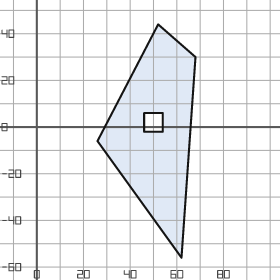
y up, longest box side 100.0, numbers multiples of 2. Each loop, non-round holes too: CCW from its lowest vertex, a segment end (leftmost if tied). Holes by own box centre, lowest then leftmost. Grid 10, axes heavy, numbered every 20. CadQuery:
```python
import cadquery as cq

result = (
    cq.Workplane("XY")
    .moveTo(62.0, -56.0)
    .lineTo(68.0, 30.0)
    .lineTo(52.0, 44.0)
    .lineTo(26.0, -6.0)
    .close()
    .moveTo(46.0, -2.0)
    .lineTo(54.0, -2.0)
    .lineTo(54.0, 6.0)
    .lineTo(46.0, 6.0)
    .close()
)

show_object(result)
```